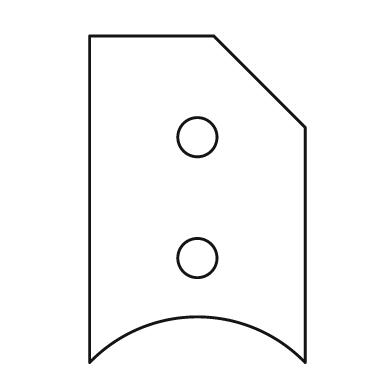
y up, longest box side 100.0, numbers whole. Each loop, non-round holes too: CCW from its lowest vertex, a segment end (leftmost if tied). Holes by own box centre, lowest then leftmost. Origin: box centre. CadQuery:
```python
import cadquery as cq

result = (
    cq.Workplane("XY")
    .moveTo(-33.0, -50.0)
    .threePointArc((0.0, -36.0), (33.0, -50.0))
    .lineTo(33.0, 22.0)
    .lineTo(5.0, 50.0)
    .lineTo(-33.0, 50.0)
    .close()
    .moveTo(0.0, -18.0)
    .circle(6.0)
    .moveTo(0.0, 19.0)
    .circle(6.0)
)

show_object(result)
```